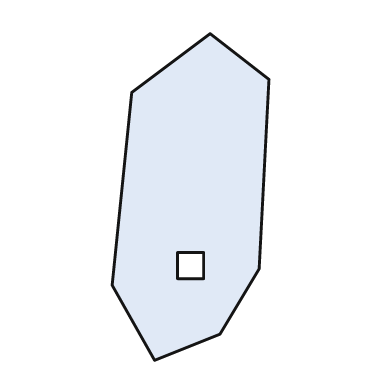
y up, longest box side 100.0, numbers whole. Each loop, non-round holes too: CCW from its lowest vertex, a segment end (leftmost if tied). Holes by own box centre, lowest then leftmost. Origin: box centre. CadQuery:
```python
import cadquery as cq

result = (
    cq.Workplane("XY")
    .moveTo(-11.0, -50.0)
    .lineTo(9.0, -42.0)
    .lineTo(21.0, -22.0)
    .lineTo(24.0, 36.0)
    .lineTo(6.0, 50.0)
    .lineTo(-18.0, 32.0)
    .lineTo(-24.0, -27.0)
    .close()
    .moveTo(-4.0, -25.0)
    .lineTo(4.0, -25.0)
    .lineTo(4.0, -17.0)
    .lineTo(-4.0, -17.0)
    .close()
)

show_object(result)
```